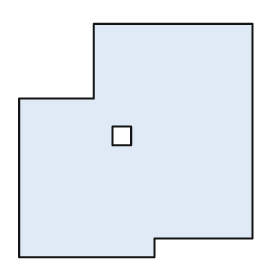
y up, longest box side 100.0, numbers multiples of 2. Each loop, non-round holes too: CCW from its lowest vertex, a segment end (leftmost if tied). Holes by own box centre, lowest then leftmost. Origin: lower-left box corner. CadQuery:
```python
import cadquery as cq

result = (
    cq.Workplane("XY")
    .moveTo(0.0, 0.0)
    .lineTo(58.0, 0.0)
    .lineTo(58.0, 8.0)
    .lineTo(100.0, 8.0)
    .lineTo(100.0, 100.0)
    .lineTo(32.0, 100.0)
    .lineTo(32.0, 68.0)
    .lineTo(0.0, 68.0)
    .close()
    .moveTo(40.0, 48.0)
    .lineTo(48.0, 48.0)
    .lineTo(48.0, 56.0)
    .lineTo(40.0, 56.0)
    .close()
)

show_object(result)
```